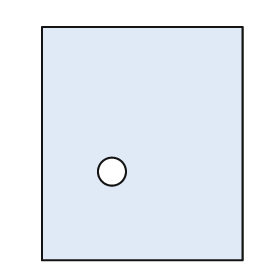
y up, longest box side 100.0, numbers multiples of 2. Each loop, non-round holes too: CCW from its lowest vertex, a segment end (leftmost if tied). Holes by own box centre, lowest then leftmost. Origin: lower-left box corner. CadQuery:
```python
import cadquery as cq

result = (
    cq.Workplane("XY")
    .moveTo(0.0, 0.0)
    .lineTo(86.0, 0.0)
    .lineTo(86.0, 100.0)
    .lineTo(0.0, 100.0)
    .close()
    .moveTo(30.0, 38.0)
    .circle(6.0)
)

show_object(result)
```